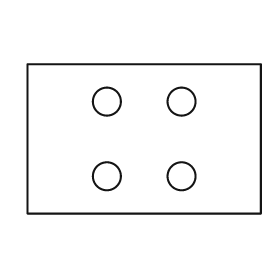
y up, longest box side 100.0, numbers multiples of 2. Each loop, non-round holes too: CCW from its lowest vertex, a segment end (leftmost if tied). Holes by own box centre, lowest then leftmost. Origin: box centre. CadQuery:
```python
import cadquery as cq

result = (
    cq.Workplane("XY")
    .moveTo(-50.0, -32.0)
    .lineTo(50.0, -32.0)
    .lineTo(50.0, 32.0)
    .lineTo(-50.0, 32.0)
    .close()
    .moveTo(-16.0, -16.0)
    .circle(6.0)
    .moveTo(16.0, -16.0)
    .circle(6.0)
    .moveTo(-16.0, 16.0)
    .circle(6.0)
    .moveTo(16.0, 16.0)
    .circle(6.0)
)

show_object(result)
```